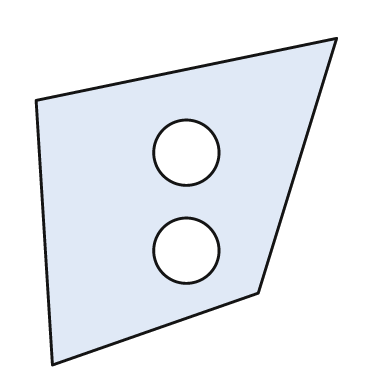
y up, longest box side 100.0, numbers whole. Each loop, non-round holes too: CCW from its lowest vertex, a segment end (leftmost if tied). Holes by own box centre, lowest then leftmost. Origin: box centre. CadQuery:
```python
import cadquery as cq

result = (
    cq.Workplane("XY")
    .moveTo(-41.0, -50.0)
    .lineTo(22.0, -28.0)
    .lineTo(46.0, 50.0)
    .lineTo(-46.0, 31.0)
    .close()
    .moveTo(0.0, -15.0)
    .circle(10.0)
    .moveTo(0.0, 15.0)
    .circle(10.0)
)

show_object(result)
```